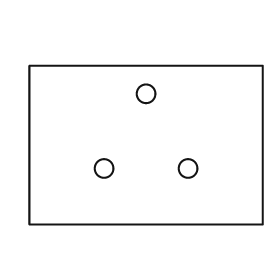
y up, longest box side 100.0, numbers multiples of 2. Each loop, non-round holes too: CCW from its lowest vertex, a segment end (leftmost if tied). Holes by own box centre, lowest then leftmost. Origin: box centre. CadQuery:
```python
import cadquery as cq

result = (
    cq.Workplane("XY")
    .moveTo(-50.0, -34.0)
    .lineTo(50.0, -34.0)
    .lineTo(50.0, 34.0)
    .lineTo(-50.0, 34.0)
    .close()
    .moveTo(-18.0, -10.0)
    .circle(4.0)
    .moveTo(18.0, -10.0)
    .circle(4.0)
    .moveTo(0.0, 22.0)
    .circle(4.0)
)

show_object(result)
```